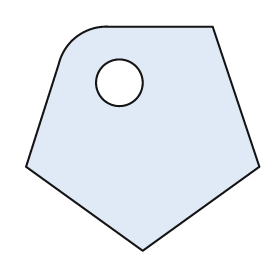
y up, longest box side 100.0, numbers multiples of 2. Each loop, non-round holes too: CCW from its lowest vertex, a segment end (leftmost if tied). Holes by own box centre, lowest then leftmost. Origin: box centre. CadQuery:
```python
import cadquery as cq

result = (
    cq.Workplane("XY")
    .moveTo(0.0, -48.0)
    .lineTo(50.0, -12.0)
    .lineTo(30.0, 48.0)
    .lineTo(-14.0, 48.0)
    .threePointArc((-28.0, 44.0), (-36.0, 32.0))
    .lineTo(-50.0, -12.0)
    .close()
    .moveTo(-10.0, 24.0)
    .circle(10.0)
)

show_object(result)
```